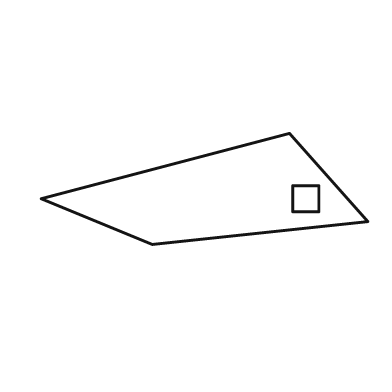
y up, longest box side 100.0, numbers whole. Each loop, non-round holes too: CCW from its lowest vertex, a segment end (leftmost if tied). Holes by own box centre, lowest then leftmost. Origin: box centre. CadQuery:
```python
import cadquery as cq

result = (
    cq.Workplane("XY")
    .moveTo(-16.0, -17.0)
    .lineTo(50.0, -10.0)
    .lineTo(26.0, 17.0)
    .lineTo(-50.0, -3.0)
    .close()
    .moveTo(27.0, -7.0)
    .lineTo(35.0, -7.0)
    .lineTo(35.0, 1.0)
    .lineTo(27.0, 1.0)
    .close()
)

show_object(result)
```